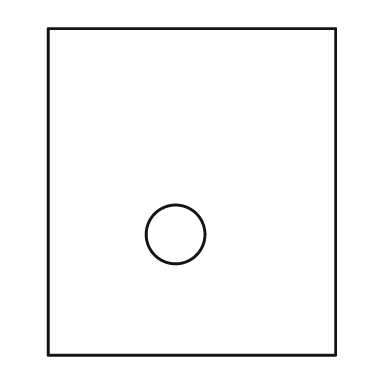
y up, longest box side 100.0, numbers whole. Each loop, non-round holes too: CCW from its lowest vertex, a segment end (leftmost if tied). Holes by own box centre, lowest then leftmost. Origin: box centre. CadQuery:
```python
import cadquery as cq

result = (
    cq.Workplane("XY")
    .moveTo(-44.0, -50.0)
    .lineTo(44.0, -50.0)
    .lineTo(44.0, 50.0)
    .lineTo(-44.0, 50.0)
    .close()
    .moveTo(-5.0, -13.0)
    .circle(9.0)
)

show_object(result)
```